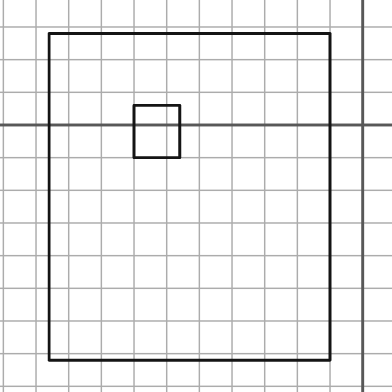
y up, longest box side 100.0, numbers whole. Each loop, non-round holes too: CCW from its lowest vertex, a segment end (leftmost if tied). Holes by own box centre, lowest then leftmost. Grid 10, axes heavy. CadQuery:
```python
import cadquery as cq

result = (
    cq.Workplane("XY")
    .moveTo(-96.0, -72.0)
    .lineTo(-10.0, -72.0)
    .lineTo(-10.0, 28.0)
    .lineTo(-96.0, 28.0)
    .close()
    .moveTo(-70.0, -10.0)
    .lineTo(-56.0, -10.0)
    .lineTo(-56.0, 6.0)
    .lineTo(-70.0, 6.0)
    .close()
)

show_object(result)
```